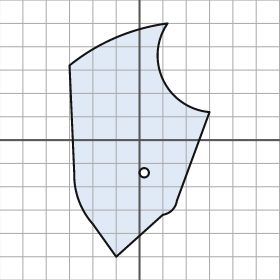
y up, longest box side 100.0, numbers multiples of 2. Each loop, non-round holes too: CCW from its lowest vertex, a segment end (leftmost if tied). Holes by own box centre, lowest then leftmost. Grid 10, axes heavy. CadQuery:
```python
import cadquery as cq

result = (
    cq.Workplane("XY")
    .moveTo(-10.0, -50.0)
    .lineTo(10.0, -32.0)
    .threePointArc((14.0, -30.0), (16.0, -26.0))
    .lineTo(30.0, 12.0)
    .threePointArc((10.0, 26.0), (12.0, 50.0))
    .threePointArc((-10.0, 44.0), (-30.0, 32.0))
    .lineTo(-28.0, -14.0)
    .threePointArc((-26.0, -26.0), (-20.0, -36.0))
    .close()
    .moveTo(2.0, -14.0)
    .circle(2.0)
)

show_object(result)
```